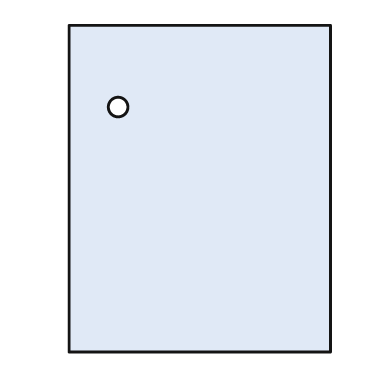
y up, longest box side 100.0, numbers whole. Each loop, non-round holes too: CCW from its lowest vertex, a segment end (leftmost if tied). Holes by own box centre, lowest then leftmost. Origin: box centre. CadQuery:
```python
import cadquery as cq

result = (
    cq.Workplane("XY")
    .moveTo(-40.0, -50.0)
    .lineTo(40.0, -50.0)
    .lineTo(40.0, 50.0)
    .lineTo(-40.0, 50.0)
    .close()
    .moveTo(-25.0, 25.0)
    .circle(3.0)
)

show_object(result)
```